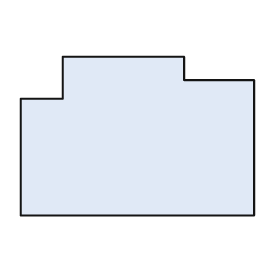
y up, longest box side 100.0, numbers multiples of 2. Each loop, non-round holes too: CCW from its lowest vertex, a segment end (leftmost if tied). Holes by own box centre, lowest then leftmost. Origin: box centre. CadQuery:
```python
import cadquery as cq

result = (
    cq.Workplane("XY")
    .moveTo(-50.0, -34.0)
    .lineTo(50.0, -34.0)
    .lineTo(50.0, 24.0)
    .lineTo(20.0, 24.0)
    .lineTo(20.0, 34.0)
    .lineTo(-32.0, 34.0)
    .lineTo(-32.0, 16.0)
    .lineTo(-50.0, 16.0)
    .close()
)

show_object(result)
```